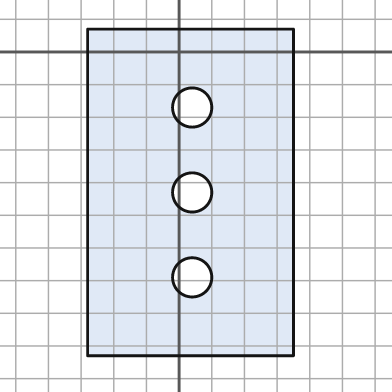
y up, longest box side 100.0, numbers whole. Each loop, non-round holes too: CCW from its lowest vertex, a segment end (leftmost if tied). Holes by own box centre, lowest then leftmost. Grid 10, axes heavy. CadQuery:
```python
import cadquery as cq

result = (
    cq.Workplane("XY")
    .moveTo(-28.0, -93.0)
    .lineTo(35.0, -93.0)
    .lineTo(35.0, 7.0)
    .lineTo(-28.0, 7.0)
    .close()
    .moveTo(4.0, -69.0)
    .circle(6.0)
    .moveTo(4.0, -43.0)
    .circle(6.0)
    .moveTo(4.0, -17.0)
    .circle(6.0)
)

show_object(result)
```